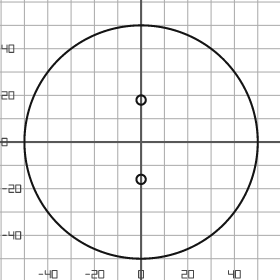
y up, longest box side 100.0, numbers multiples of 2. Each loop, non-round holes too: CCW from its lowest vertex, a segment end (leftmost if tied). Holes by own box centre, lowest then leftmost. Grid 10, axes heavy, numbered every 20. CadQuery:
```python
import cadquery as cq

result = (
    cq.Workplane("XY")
    .moveTo(0.0, 0.0)
    .circle(50.0)
    .moveTo(0.0, -16.0)
    .circle(2.0)
    .moveTo(0.0, 18.0)
    .circle(2.0)
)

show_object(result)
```